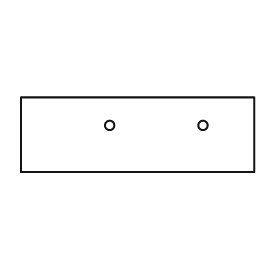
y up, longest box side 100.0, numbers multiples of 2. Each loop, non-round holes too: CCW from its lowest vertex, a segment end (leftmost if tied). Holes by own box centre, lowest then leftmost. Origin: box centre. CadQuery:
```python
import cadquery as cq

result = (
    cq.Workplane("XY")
    .moveTo(-50.0, -16.0)
    .lineTo(50.0, -16.0)
    .lineTo(50.0, 16.0)
    .lineTo(-50.0, 16.0)
    .close()
    .moveTo(-12.0, 4.0)
    .circle(2.0)
    .moveTo(28.0, 4.0)
    .circle(2.0)
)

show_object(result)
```